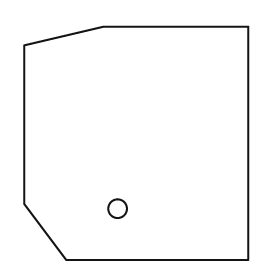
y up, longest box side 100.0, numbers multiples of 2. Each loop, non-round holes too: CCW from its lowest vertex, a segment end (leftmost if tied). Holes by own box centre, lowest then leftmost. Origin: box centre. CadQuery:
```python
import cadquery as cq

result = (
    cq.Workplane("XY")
    .moveTo(-30.0, -50.0)
    .lineTo(48.0, -50.0)
    .lineTo(48.0, 50.0)
    .lineTo(-14.0, 50.0)
    .lineTo(-48.0, 42.0)
    .lineTo(-48.0, -26.0)
    .close()
    .moveTo(-8.0, -28.0)
    .circle(4.0)
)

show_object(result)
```